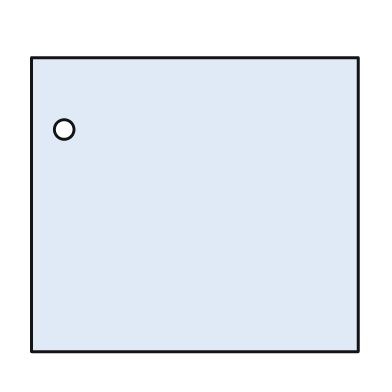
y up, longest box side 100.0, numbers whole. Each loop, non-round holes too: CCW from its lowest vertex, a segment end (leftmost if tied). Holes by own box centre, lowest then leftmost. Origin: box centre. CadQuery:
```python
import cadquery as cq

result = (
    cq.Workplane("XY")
    .moveTo(-50.0, -45.0)
    .lineTo(50.0, -45.0)
    .lineTo(50.0, 45.0)
    .lineTo(-50.0, 45.0)
    .close()
    .moveTo(-40.0, 23.0)
    .circle(3.0)
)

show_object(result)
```